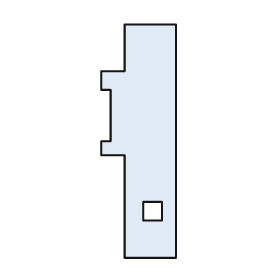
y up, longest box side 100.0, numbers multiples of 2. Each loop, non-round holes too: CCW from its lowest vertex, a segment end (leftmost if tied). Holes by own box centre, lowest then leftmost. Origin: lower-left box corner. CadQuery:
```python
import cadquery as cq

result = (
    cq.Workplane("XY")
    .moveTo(10.0, 0.0)
    .lineTo(32.0, 0.0)
    .lineTo(32.0, 100.0)
    .lineTo(10.0, 100.0)
    .lineTo(10.0, 80.0)
    .lineTo(0.0, 80.0)
    .lineTo(0.0, 72.0)
    .lineTo(4.0, 72.0)
    .lineTo(4.0, 50.0)
    .lineTo(0.0, 50.0)
    .lineTo(0.0, 44.0)
    .lineTo(10.0, 44.0)
    .close()
    .moveTo(18.0, 16.0)
    .lineTo(26.0, 16.0)
    .lineTo(26.0, 24.0)
    .lineTo(18.0, 24.0)
    .close()
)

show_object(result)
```